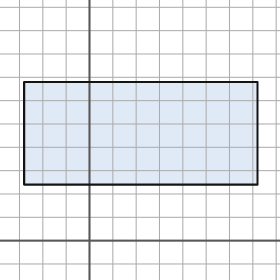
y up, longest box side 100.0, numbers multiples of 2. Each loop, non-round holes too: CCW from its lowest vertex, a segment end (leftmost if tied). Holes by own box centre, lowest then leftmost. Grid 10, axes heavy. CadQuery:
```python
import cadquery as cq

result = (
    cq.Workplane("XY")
    .moveTo(-28.0, 24.0)
    .lineTo(72.0, 24.0)
    .lineTo(72.0, 68.0)
    .lineTo(-28.0, 68.0)
    .close()
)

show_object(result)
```